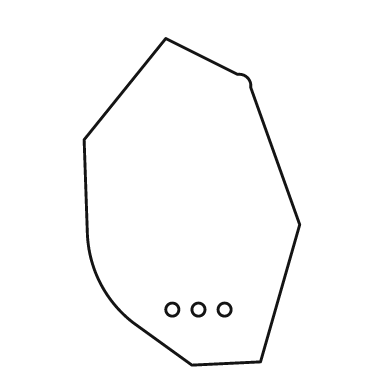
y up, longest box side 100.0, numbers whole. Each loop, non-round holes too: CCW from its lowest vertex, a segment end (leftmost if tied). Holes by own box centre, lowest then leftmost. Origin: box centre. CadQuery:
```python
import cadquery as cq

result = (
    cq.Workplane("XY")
    .moveTo(0.0, -50.0)
    .lineTo(21.0, -49.0)
    .lineTo(33.0, -7.0)
    .lineTo(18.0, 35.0)
    .threePointArc((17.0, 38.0), (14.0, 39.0))
    .lineTo(-8.0, 50.0)
    .lineTo(-33.0, 19.0)
    .lineTo(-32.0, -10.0)
    .threePointArc((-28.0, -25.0), (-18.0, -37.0))
    .close()
    .moveTo(-6.0, -33.0)
    .circle(2.0)
    .moveTo(2.0, -33.0)
    .circle(2.0)
    .moveTo(10.0, -33.0)
    .circle(2.0)
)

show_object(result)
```